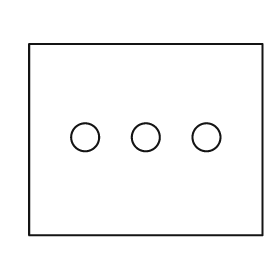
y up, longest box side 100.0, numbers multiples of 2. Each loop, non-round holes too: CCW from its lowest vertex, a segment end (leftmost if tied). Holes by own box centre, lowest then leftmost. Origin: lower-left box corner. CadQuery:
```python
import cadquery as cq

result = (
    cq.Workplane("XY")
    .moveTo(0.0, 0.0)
    .lineTo(100.0, 0.0)
    .lineTo(100.0, 82.0)
    .lineTo(0.0, 82.0)
    .close()
    .moveTo(24.0, 42.0)
    .circle(6.0)
    .moveTo(50.0, 42.0)
    .circle(6.0)
    .moveTo(76.0, 42.0)
    .circle(6.0)
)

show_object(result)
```